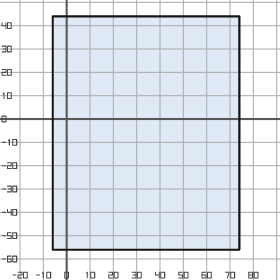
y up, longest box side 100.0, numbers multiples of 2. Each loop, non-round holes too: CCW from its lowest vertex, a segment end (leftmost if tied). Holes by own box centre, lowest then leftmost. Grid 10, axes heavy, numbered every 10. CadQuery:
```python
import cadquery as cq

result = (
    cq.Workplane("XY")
    .moveTo(-6.0, -56.0)
    .lineTo(74.0, -56.0)
    .lineTo(74.0, 44.0)
    .lineTo(-6.0, 44.0)
    .close()
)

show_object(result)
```